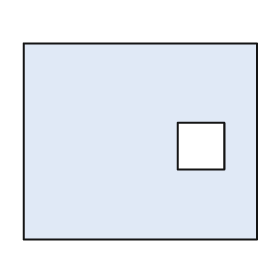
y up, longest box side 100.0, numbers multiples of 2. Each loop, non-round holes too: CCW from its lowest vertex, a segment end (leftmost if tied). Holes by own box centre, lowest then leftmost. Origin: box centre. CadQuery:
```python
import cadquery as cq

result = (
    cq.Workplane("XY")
    .moveTo(-50.0, -42.0)
    .lineTo(50.0, -42.0)
    .lineTo(50.0, 42.0)
    .lineTo(-50.0, 42.0)
    .close()
    .moveTo(16.0, -12.0)
    .lineTo(36.0, -12.0)
    .lineTo(36.0, 8.0)
    .lineTo(16.0, 8.0)
    .close()
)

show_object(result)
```